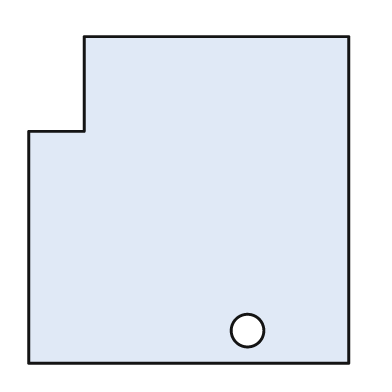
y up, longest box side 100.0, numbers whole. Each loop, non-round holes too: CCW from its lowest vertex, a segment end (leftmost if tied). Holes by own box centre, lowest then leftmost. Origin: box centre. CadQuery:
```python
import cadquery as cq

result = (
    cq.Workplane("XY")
    .moveTo(-49.0, -50.0)
    .lineTo(49.0, -50.0)
    .lineTo(49.0, 50.0)
    .lineTo(-32.0, 50.0)
    .lineTo(-32.0, 21.0)
    .lineTo(-49.0, 21.0)
    .close()
    .moveTo(18.0, -40.0)
    .circle(5.0)
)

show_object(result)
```